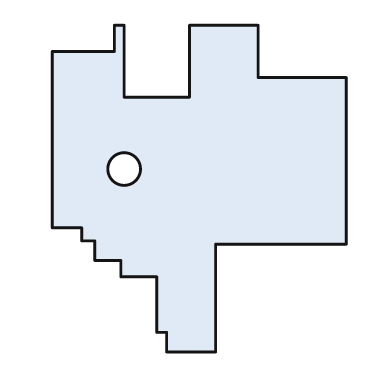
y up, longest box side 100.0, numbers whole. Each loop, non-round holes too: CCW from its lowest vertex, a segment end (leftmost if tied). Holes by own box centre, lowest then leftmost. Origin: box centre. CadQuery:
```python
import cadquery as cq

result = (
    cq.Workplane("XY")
    .moveTo(-10.0, -50.0)
    .lineTo(5.0, -50.0)
    .lineTo(5.0, -17.0)
    .lineTo(45.0, -17.0)
    .lineTo(45.0, 34.0)
    .lineTo(18.0, 34.0)
    .lineTo(18.0, 50.0)
    .lineTo(-3.0, 50.0)
    .lineTo(-3.0, 28.0)
    .lineTo(-23.0, 28.0)
    .lineTo(-23.0, 50.0)
    .lineTo(-26.0, 50.0)
    .lineTo(-26.0, 42.0)
    .lineTo(-45.0, 42.0)
    .lineTo(-45.0, -12.0)
    .lineTo(-36.0, -12.0)
    .lineTo(-36.0, -16.0)
    .lineTo(-32.0, -16.0)
    .lineTo(-32.0, -22.0)
    .lineTo(-24.0, -22.0)
    .lineTo(-24.0, -27.0)
    .lineTo(-13.0, -27.0)
    .lineTo(-13.0, -44.0)
    .lineTo(-10.0, -44.0)
    .close()
    .moveTo(-23.0, 6.0)
    .circle(5.0)
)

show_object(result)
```